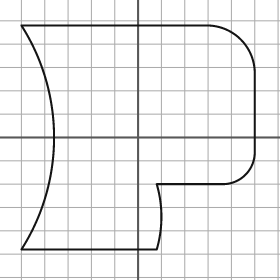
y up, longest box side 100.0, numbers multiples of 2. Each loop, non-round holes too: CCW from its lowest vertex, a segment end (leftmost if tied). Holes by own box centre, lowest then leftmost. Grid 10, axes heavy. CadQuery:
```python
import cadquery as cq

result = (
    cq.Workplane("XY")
    .moveTo(-50.0, -48.0)
    .lineTo(8.0, -48.0)
    .threePointArc((10.0, -34.0), (8.0, -20.0))
    .lineTo(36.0, -20.0)
    .threePointArc((46.0, -16.0), (50.0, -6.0))
    .lineTo(50.0, 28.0)
    .threePointArc((44.0, 42.0), (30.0, 48.0))
    .lineTo(-50.0, 48.0)
    .threePointArc((-36.0, 0.0), (-50.0, -48.0))
    .close()
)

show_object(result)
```